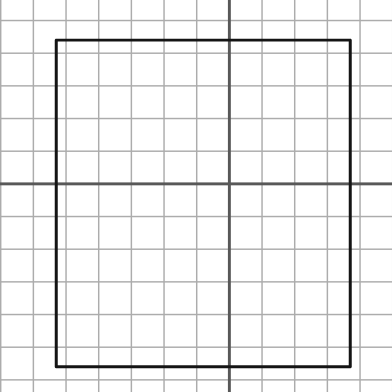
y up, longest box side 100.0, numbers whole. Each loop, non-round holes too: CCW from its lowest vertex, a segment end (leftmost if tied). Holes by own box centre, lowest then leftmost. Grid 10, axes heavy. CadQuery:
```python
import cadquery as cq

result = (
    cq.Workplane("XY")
    .moveTo(-53.0, -56.0)
    .lineTo(37.0, -56.0)
    .lineTo(37.0, 44.0)
    .lineTo(-53.0, 44.0)
    .close()
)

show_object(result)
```